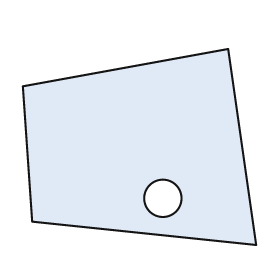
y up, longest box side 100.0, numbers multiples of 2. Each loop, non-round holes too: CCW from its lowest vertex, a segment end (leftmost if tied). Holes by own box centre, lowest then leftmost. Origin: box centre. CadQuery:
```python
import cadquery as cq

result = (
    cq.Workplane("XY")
    .moveTo(50.0, -42.0)
    .lineTo(38.0, 42.0)
    .lineTo(-50.0, 26.0)
    .lineTo(-46.0, -32.0)
    .close()
    .moveTo(10.0, -22.0)
    .circle(8.0)
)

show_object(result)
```